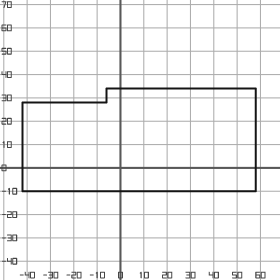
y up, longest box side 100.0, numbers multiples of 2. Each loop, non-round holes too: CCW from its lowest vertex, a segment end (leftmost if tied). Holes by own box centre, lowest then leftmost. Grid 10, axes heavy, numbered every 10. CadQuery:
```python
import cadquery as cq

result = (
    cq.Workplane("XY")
    .moveTo(-42.0, -10.0)
    .lineTo(58.0, -10.0)
    .lineTo(58.0, 34.0)
    .lineTo(-6.0, 34.0)
    .lineTo(-6.0, 28.0)
    .lineTo(-42.0, 28.0)
    .close()
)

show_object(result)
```